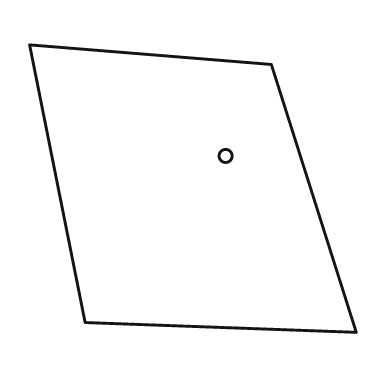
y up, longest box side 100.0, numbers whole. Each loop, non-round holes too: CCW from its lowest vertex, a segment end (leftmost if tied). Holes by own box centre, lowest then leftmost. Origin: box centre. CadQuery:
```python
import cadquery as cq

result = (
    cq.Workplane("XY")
    .moveTo(50.0, -44.0)
    .lineTo(24.0, 38.0)
    .lineTo(-50.0, 44.0)
    .lineTo(-33.0, -41.0)
    .close()
    .moveTo(10.0, 10.0)
    .circle(2.0)
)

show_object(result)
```